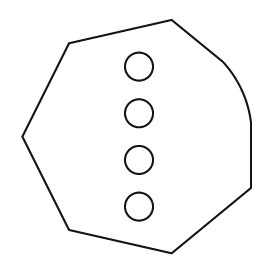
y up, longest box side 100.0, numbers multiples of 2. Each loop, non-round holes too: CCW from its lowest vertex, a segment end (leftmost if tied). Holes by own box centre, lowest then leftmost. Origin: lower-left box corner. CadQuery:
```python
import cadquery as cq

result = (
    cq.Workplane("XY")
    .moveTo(64.0, 0.0)
    .lineTo(98.0, 28.0)
    .lineTo(98.0, 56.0)
    .threePointArc((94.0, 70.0), (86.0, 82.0))
    .lineTo(64.0, 100.0)
    .lineTo(20.0, 90.0)
    .lineTo(0.0, 50.0)
    .lineTo(20.0, 10.0)
    .close()
    .moveTo(50.0, 20.0)
    .circle(6.0)
    .moveTo(50.0, 40.0)
    .circle(6.0)
    .moveTo(50.0, 60.0)
    .circle(6.0)
    .moveTo(50.0, 80.0)
    .circle(6.0)
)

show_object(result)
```